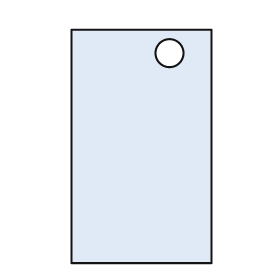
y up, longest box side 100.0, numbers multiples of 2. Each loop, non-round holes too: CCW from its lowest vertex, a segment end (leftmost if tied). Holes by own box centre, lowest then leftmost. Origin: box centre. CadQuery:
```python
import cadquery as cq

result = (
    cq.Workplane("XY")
    .moveTo(-30.0, -50.0)
    .lineTo(30.0, -50.0)
    .lineTo(30.0, 50.0)
    .lineTo(-30.0, 50.0)
    .close()
    .moveTo(12.0, 40.0)
    .circle(6.0)
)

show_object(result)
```